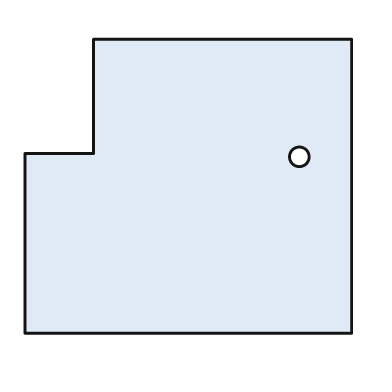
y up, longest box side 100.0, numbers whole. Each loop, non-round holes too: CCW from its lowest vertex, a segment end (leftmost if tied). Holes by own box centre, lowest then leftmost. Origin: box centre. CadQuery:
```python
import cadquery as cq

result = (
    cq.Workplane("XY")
    .moveTo(-50.0, -45.0)
    .lineTo(50.0, -45.0)
    .lineTo(50.0, 45.0)
    .lineTo(-29.0, 45.0)
    .lineTo(-29.0, 10.0)
    .lineTo(-50.0, 10.0)
    .close()
    .moveTo(34.0, 9.0)
    .circle(3.0)
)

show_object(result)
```